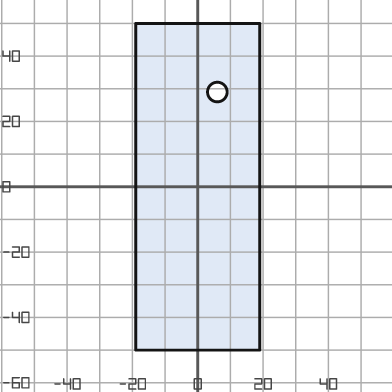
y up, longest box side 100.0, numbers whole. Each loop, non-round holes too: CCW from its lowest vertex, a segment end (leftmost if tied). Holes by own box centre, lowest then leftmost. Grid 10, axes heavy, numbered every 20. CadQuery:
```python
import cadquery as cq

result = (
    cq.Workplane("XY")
    .moveTo(-19.0, -50.0)
    .lineTo(19.0, -50.0)
    .lineTo(19.0, 50.0)
    .lineTo(-19.0, 50.0)
    .close()
    .moveTo(6.0, 29.0)
    .circle(3.0)
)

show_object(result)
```